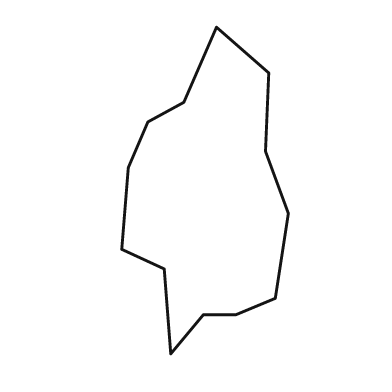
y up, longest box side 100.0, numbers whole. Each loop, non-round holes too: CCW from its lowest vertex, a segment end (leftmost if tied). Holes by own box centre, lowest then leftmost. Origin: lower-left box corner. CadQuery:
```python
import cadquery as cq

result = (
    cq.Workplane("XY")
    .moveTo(15.0, 0.0)
    .lineTo(25.0, 12.0)
    .lineTo(35.0, 12.0)
    .lineTo(47.0, 17.0)
    .lineTo(51.0, 43.0)
    .lineTo(44.0, 62.0)
    .lineTo(45.0, 86.0)
    .lineTo(29.0, 100.0)
    .lineTo(19.0, 77.0)
    .lineTo(8.0, 71.0)
    .lineTo(2.0, 57.0)
    .lineTo(0.0, 32.0)
    .lineTo(13.0, 26.0)
    .close()
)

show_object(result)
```